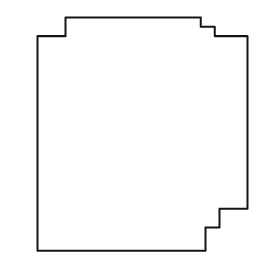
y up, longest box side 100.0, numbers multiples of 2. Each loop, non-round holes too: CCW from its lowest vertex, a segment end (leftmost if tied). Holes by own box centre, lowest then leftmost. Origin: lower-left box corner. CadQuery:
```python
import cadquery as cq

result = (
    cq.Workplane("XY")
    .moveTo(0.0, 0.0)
    .lineTo(72.0, 0.0)
    .lineTo(72.0, 10.0)
    .lineTo(78.0, 10.0)
    .lineTo(78.0, 18.0)
    .lineTo(90.0, 18.0)
    .lineTo(90.0, 92.0)
    .lineTo(76.0, 92.0)
    .lineTo(76.0, 96.0)
    .lineTo(70.0, 96.0)
    .lineTo(70.0, 100.0)
    .lineTo(12.0, 100.0)
    .lineTo(12.0, 92.0)
    .lineTo(0.0, 92.0)
    .close()
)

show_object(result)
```